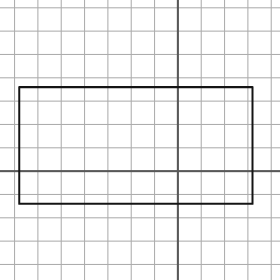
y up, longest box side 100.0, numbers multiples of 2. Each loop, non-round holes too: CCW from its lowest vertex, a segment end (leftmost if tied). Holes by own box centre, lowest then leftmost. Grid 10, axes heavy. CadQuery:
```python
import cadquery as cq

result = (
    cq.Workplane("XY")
    .moveTo(-68.0, -14.0)
    .lineTo(32.0, -14.0)
    .lineTo(32.0, 36.0)
    .lineTo(-68.0, 36.0)
    .close()
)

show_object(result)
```